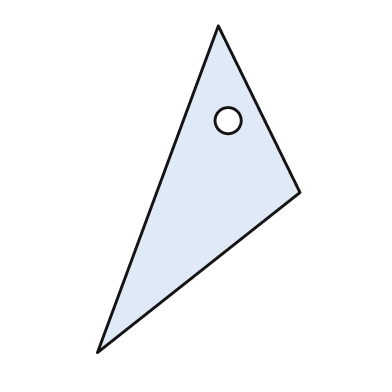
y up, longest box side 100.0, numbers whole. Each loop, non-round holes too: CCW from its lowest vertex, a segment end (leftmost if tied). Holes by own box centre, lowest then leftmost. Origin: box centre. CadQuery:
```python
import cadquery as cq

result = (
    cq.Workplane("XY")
    .moveTo(-31.0, -50.0)
    .lineTo(31.0, -1.0)
    .lineTo(6.0, 50.0)
    .close()
    .moveTo(9.0, 21.0)
    .circle(4.0)
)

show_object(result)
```